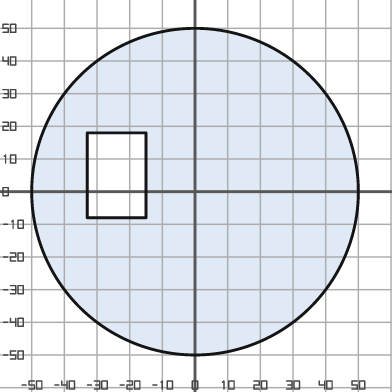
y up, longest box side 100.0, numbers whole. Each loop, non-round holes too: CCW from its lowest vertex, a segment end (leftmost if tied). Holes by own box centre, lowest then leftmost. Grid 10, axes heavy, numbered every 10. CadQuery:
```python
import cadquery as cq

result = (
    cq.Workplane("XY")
    .moveTo(0.0, 0.0)
    .circle(50.0)
    .moveTo(-33.0, -8.0)
    .lineTo(-15.0, -8.0)
    .lineTo(-15.0, 18.0)
    .lineTo(-33.0, 18.0)
    .close()
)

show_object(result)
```